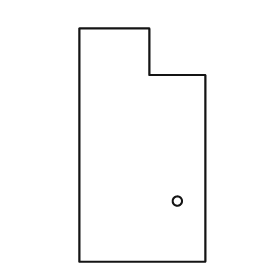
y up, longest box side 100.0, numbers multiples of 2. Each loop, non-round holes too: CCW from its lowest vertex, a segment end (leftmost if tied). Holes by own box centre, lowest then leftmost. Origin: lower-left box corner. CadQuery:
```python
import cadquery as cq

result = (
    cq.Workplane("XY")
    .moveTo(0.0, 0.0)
    .lineTo(54.0, 0.0)
    .lineTo(54.0, 80.0)
    .lineTo(30.0, 80.0)
    .lineTo(30.0, 100.0)
    .lineTo(0.0, 100.0)
    .close()
    .moveTo(42.0, 26.0)
    .circle(2.0)
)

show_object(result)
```